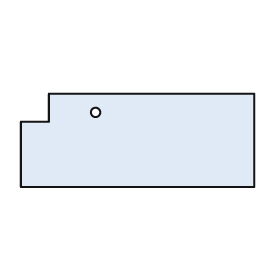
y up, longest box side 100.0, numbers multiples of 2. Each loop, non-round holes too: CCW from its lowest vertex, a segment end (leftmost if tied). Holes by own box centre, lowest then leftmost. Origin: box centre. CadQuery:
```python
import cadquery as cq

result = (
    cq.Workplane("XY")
    .moveTo(-50.0, -20.0)
    .lineTo(50.0, -20.0)
    .lineTo(50.0, 20.0)
    .lineTo(-38.0, 20.0)
    .lineTo(-38.0, 8.0)
    .lineTo(-50.0, 8.0)
    .close()
    .moveTo(-18.0, 12.0)
    .circle(2.0)
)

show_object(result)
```